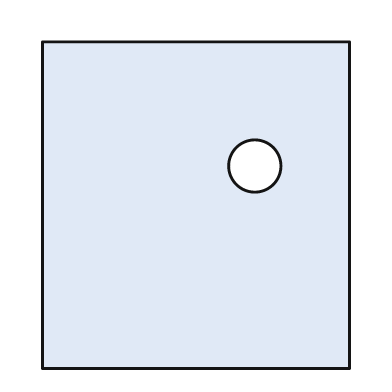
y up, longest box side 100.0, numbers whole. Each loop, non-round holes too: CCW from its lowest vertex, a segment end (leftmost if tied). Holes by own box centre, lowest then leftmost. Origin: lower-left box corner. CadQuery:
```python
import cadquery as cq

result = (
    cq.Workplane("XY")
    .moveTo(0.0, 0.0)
    .lineTo(94.0, 0.0)
    .lineTo(94.0, 100.0)
    .lineTo(0.0, 100.0)
    .close()
    .moveTo(65.0, 62.0)
    .circle(8.0)
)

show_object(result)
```